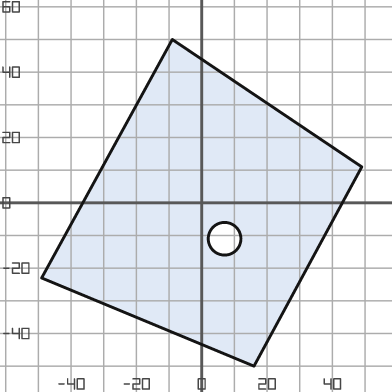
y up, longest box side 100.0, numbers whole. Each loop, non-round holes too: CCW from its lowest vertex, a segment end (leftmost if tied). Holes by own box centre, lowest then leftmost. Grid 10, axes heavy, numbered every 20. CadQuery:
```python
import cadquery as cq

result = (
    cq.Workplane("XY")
    .moveTo(16.0, -50.0)
    .lineTo(49.0, 11.0)
    .lineTo(-9.0, 50.0)
    .lineTo(-49.0, -23.0)
    .close()
    .moveTo(7.0, -11.0)
    .circle(5.0)
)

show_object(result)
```